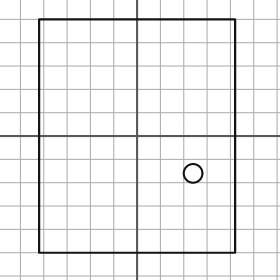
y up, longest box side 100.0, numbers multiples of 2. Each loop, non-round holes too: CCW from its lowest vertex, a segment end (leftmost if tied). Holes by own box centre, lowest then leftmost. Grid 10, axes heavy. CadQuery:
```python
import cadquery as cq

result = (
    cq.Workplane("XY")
    .moveTo(-42.0, -50.0)
    .lineTo(42.0, -50.0)
    .lineTo(42.0, 50.0)
    .lineTo(-42.0, 50.0)
    .close()
    .moveTo(24.0, -16.0)
    .circle(4.0)
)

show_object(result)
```